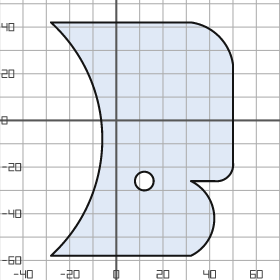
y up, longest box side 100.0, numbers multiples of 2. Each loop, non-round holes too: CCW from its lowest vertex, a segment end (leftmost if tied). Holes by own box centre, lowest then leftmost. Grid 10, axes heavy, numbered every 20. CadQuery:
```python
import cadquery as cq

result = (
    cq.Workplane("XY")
    .moveTo(-28.0, -58.0)
    .lineTo(32.0, -58.0)
    .threePointArc((42.0, -42.0), (32.0, -26.0))
    .lineTo(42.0, -26.0)
    .threePointArc((48.0, -24.0), (50.0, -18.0))
    .lineTo(50.0, 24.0)
    .threePointArc((44.0, 36.0), (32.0, 42.0))
    .lineTo(-28.0, 42.0)
    .threePointArc((-6.0, -8.0), (-28.0, -58.0))
    .close()
    .moveTo(12.0, -26.0)
    .circle(4.0)
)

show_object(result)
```